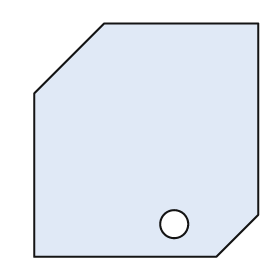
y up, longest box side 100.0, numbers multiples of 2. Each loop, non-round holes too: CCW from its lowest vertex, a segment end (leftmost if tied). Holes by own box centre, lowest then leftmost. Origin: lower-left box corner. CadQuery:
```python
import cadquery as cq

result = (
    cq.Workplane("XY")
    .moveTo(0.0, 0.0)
    .lineTo(78.0, 0.0)
    .lineTo(96.0, 18.0)
    .lineTo(96.0, 100.0)
    .lineTo(30.0, 100.0)
    .lineTo(0.0, 70.0)
    .close()
    .moveTo(60.0, 14.0)
    .circle(6.0)
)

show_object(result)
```